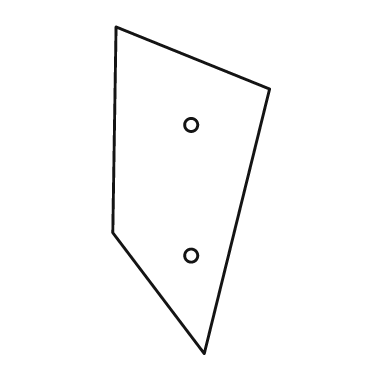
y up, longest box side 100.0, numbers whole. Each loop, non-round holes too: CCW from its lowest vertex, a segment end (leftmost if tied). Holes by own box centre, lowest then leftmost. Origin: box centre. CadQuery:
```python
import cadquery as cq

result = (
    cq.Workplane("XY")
    .moveTo(4.0, -50.0)
    .lineTo(24.0, 31.0)
    .lineTo(-23.0, 50.0)
    .lineTo(-24.0, -13.0)
    .close()
    .moveTo(0.0, -20.0)
    .circle(2.0)
    .moveTo(0.0, 20.0)
    .circle(2.0)
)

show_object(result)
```